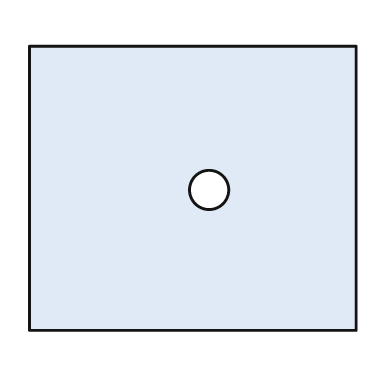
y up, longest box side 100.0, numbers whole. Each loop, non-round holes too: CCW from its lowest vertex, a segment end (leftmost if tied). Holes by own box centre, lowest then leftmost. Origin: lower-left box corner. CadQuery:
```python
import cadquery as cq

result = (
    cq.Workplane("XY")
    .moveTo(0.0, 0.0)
    .lineTo(100.0, 0.0)
    .lineTo(100.0, 87.0)
    .lineTo(0.0, 87.0)
    .close()
    .moveTo(55.0, 43.0)
    .circle(6.0)
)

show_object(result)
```